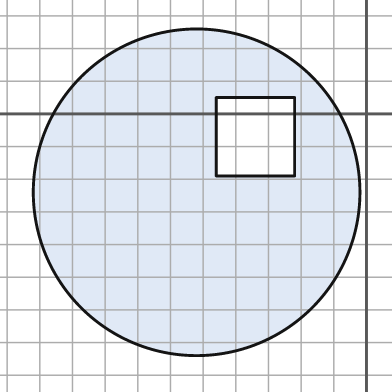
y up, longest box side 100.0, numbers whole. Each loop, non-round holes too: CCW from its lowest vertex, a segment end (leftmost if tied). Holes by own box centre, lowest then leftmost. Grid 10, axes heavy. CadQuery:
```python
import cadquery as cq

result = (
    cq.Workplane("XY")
    .moveTo(-52.0, -24.0)
    .circle(50.0)
    .moveTo(-46.0, -19.0)
    .lineTo(-22.0, -19.0)
    .lineTo(-22.0, 5.0)
    .lineTo(-46.0, 5.0)
    .close()
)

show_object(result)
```